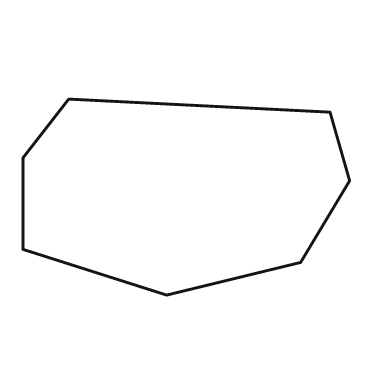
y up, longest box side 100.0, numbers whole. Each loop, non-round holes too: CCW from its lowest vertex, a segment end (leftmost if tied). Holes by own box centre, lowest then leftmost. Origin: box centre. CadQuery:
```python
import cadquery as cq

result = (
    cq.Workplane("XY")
    .moveTo(-6.0, -30.0)
    .lineTo(35.0, -20.0)
    .lineTo(50.0, 5.0)
    .lineTo(44.0, 26.0)
    .lineTo(-36.0, 30.0)
    .lineTo(-50.0, 12.0)
    .lineTo(-50.0, -16.0)
    .close()
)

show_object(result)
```